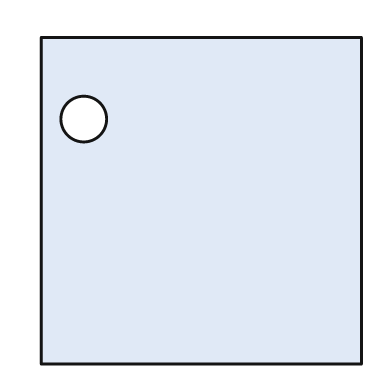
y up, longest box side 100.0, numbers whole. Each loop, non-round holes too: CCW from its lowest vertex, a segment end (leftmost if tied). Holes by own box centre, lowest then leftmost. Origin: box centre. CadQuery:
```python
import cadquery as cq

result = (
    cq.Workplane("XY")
    .moveTo(-49.0, -50.0)
    .lineTo(49.0, -50.0)
    .lineTo(49.0, 50.0)
    .lineTo(-49.0, 50.0)
    .close()
    .moveTo(-36.0, 25.0)
    .circle(7.0)
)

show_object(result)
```